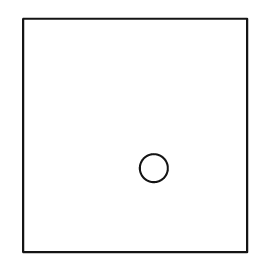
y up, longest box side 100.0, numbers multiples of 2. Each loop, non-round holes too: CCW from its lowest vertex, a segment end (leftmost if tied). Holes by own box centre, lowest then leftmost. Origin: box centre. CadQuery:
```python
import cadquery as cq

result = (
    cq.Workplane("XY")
    .moveTo(-48.0, -50.0)
    .lineTo(48.0, -50.0)
    .lineTo(48.0, 50.0)
    .lineTo(-48.0, 50.0)
    .close()
    .moveTo(8.0, -14.0)
    .circle(6.0)
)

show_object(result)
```